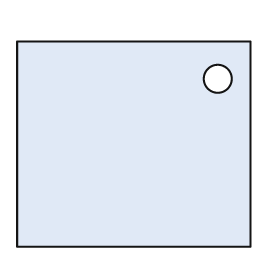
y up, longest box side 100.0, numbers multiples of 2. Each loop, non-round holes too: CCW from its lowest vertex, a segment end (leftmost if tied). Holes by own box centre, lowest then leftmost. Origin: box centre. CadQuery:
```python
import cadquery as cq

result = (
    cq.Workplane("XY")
    .moveTo(-50.0, -44.0)
    .lineTo(50.0, -44.0)
    .lineTo(50.0, 44.0)
    .lineTo(-50.0, 44.0)
    .close()
    .moveTo(36.0, 28.0)
    .circle(6.0)
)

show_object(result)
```